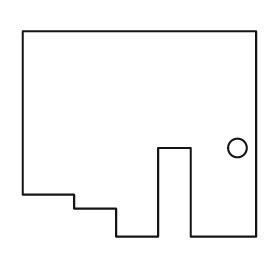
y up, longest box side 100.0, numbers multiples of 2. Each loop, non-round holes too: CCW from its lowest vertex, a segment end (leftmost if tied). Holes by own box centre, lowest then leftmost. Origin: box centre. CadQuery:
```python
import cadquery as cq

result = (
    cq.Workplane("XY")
    .moveTo(-10.0, -44.0)
    .lineTo(8.0, -44.0)
    .lineTo(8.0, -6.0)
    .lineTo(22.0, -6.0)
    .lineTo(22.0, -44.0)
    .lineTo(50.0, -44.0)
    .lineTo(50.0, 44.0)
    .lineTo(-50.0, 44.0)
    .lineTo(-50.0, -26.0)
    .lineTo(-28.0, -26.0)
    .lineTo(-28.0, -32.0)
    .lineTo(-10.0, -32.0)
    .close()
    .moveTo(42.0, -6.0)
    .circle(4.0)
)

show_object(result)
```